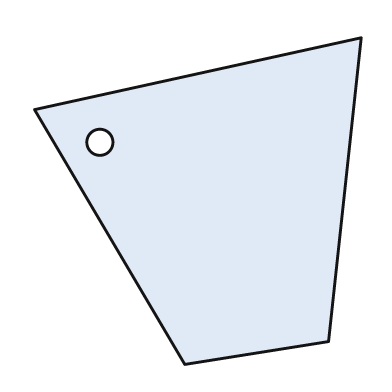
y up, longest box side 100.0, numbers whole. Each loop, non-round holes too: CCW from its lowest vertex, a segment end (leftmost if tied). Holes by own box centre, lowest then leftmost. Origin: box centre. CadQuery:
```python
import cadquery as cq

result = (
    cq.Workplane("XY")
    .moveTo(-4.0, -50.0)
    .lineTo(40.0, -43.0)
    .lineTo(50.0, 50.0)
    .lineTo(-50.0, 28.0)
    .close()
    .moveTo(-30.0, 18.0)
    .circle(4.0)
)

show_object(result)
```